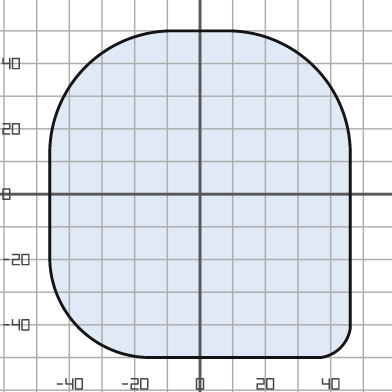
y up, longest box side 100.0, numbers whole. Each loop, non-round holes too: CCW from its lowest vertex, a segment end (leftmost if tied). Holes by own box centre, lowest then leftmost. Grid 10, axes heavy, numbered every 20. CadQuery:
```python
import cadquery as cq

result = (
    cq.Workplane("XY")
    .moveTo(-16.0, -50.0)
    .lineTo(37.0, -50.0)
    .threePointArc((43.0, -47.0), (46.0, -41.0))
    .lineTo(46.0, 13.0)
    .threePointArc((35.0, 39.0), (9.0, 50.0))
    .lineTo(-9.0, 50.0)
    .threePointArc((-35.0, 39.0), (-46.0, 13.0))
    .lineTo(-46.0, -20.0)
    .threePointArc((-37.0, -41.0), (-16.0, -50.0))
    .close()
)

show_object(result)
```